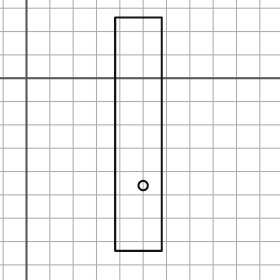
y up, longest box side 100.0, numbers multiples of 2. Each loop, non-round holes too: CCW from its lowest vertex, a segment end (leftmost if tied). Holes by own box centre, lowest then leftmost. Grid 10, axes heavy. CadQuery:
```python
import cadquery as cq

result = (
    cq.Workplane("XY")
    .moveTo(38.0, -74.0)
    .lineTo(58.0, -74.0)
    .lineTo(58.0, 26.0)
    .lineTo(38.0, 26.0)
    .close()
    .moveTo(50.0, -46.0)
    .circle(2.0)
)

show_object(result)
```